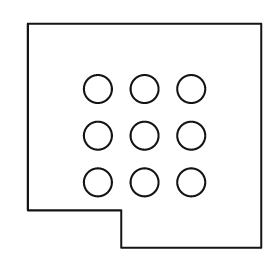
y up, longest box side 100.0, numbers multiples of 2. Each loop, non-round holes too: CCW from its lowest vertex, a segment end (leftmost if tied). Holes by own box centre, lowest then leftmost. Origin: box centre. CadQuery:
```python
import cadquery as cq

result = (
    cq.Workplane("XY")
    .moveTo(-10.0, -48.0)
    .lineTo(50.0, -48.0)
    .lineTo(50.0, 48.0)
    .lineTo(-50.0, 48.0)
    .lineTo(-50.0, -32.0)
    .lineTo(-10.0, -32.0)
    .close()
    .moveTo(-20.0, -20.0)
    .circle(6.0)
    .moveTo(0.0, -20.0)
    .circle(6.0)
    .moveTo(20.0, -20.0)
    .circle(6.0)
    .moveTo(-20.0, 0.0)
    .circle(6.0)
    .moveTo(0.0, 0.0)
    .circle(6.0)
    .moveTo(20.0, 0.0)
    .circle(6.0)
    .moveTo(-20.0, 20.0)
    .circle(6.0)
    .moveTo(0.0, 20.0)
    .circle(6.0)
    .moveTo(20.0, 20.0)
    .circle(6.0)
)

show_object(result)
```